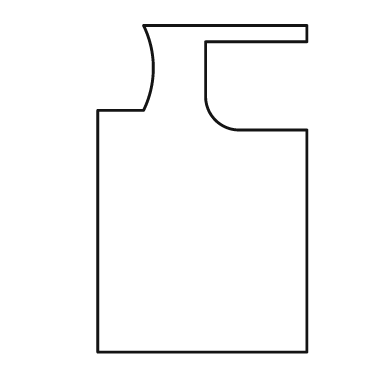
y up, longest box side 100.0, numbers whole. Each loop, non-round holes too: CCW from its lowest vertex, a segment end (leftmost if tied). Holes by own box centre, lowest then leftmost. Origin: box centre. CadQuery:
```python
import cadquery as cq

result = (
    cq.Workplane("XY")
    .moveTo(-32.0, -50.0)
    .lineTo(32.0, -50.0)
    .lineTo(32.0, 18.0)
    .lineTo(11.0, 18.0)
    .threePointArc((4.0, 21.0), (1.0, 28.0))
    .lineTo(1.0, 45.0)
    .lineTo(32.0, 45.0)
    .lineTo(32.0, 50.0)
    .lineTo(-18.0, 50.0)
    .threePointArc((-15.0, 37.0), (-18.0, 24.0))
    .lineTo(-32.0, 24.0)
    .close()
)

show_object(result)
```